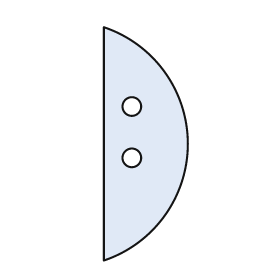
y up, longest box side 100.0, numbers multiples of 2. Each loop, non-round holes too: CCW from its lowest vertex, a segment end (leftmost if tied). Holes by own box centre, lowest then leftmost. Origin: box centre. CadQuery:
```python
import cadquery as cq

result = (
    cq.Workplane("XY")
    .moveTo(-18.0, -50.0)
    .threePointArc((18.0, 0.0), (-18.0, 50.0))
    .close()
    .moveTo(-6.0, -6.0)
    .circle(4.0)
    .moveTo(-6.0, 16.0)
    .circle(4.0)
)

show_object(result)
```